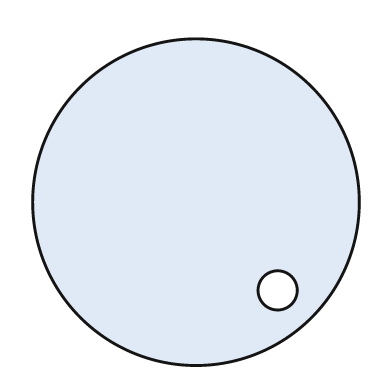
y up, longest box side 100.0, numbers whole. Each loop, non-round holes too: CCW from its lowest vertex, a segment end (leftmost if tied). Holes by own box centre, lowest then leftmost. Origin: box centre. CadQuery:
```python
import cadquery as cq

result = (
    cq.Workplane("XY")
    .moveTo(0.0, 0.0)
    .circle(50.0)
    .moveTo(25.0, -27.0)
    .circle(6.0)
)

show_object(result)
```